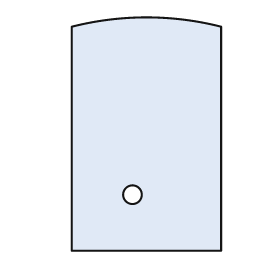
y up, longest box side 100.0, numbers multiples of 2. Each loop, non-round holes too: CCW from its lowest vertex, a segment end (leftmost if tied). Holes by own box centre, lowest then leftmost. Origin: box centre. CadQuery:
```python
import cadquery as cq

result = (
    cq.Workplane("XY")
    .moveTo(-32.0, -50.0)
    .lineTo(32.0, -50.0)
    .lineTo(32.0, 46.0)
    .threePointArc((0.0, 50.0), (-32.0, 46.0))
    .close()
    .moveTo(-6.0, -26.0)
    .circle(4.0)
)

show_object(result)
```